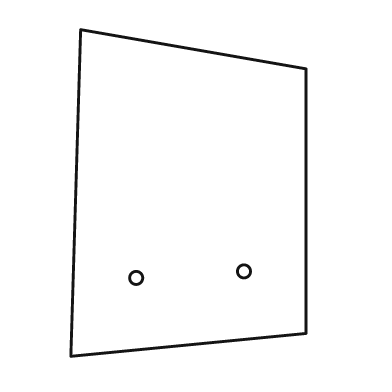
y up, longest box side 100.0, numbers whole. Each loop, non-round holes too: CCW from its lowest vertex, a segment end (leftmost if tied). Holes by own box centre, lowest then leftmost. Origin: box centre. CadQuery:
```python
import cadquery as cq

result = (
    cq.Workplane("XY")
    .moveTo(-36.0, -50.0)
    .lineTo(36.0, -43.0)
    .lineTo(36.0, 38.0)
    .lineTo(-33.0, 50.0)
    .close()
    .moveTo(-16.0, -26.0)
    .circle(2.0)
    .moveTo(17.0, -24.0)
    .circle(2.0)
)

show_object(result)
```